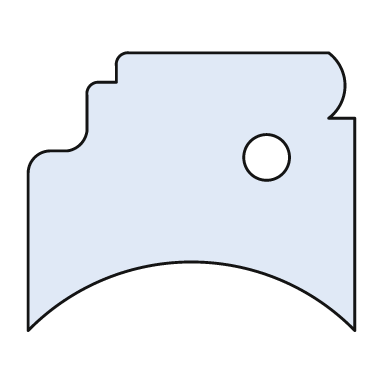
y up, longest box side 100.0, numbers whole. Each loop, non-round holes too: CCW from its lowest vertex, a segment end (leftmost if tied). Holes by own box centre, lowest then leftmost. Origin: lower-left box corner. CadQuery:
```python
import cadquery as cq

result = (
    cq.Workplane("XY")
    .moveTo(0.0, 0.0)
    .threePointArc((50.0, 21.0), (100.0, 0.0))
    .lineTo(100.0, 65.0)
    .lineTo(92.0, 65.0)
    .threePointArc((97.0, 75.0), (92.0, 85.0))
    .lineTo(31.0, 85.0)
    .threePointArc((28.0, 84.0), (27.0, 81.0))
    .lineTo(27.0, 76.0)
    .lineTo(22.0, 76.0)
    .threePointArc((19.0, 75.0), (18.0, 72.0))
    .lineTo(18.0, 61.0)
    .threePointArc((16.0, 57.0), (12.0, 55.0))
    .lineTo(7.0, 55.0)
    .threePointArc((2.0, 53.0), (0.0, 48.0))
    .close()
    .moveTo(73.0, 53.0)
    .circle(7.0)
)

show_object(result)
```